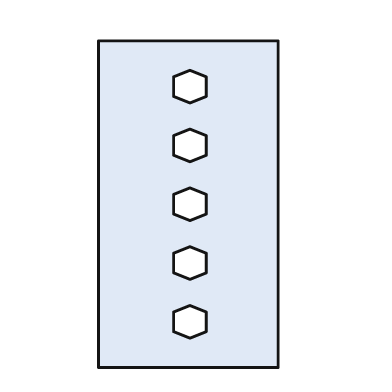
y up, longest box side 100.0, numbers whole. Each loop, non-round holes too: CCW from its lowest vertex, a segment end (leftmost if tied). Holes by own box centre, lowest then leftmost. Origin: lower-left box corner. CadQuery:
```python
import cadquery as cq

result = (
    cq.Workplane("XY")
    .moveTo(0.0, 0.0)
    .lineTo(55.0, 0.0)
    .lineTo(55.0, 100.0)
    .lineTo(0.0, 100.0)
    .close()
    .moveTo(28.0, 9.0)
    .lineTo(33.0, 11.0)
    .lineTo(33.0, 17.0)
    .lineTo(28.0, 19.0)
    .lineTo(23.0, 17.0)
    .lineTo(23.0, 11.0)
    .close()
    .moveTo(28.0, 27.0)
    .lineTo(33.0, 29.0)
    .lineTo(33.0, 35.0)
    .lineTo(28.0, 37.0)
    .lineTo(23.0, 35.0)
    .lineTo(23.0, 29.0)
    .close()
    .moveTo(28.0, 45.0)
    .lineTo(33.0, 47.0)
    .lineTo(33.0, 53.0)
    .lineTo(28.0, 55.0)
    .lineTo(23.0, 53.0)
    .lineTo(23.0, 47.0)
    .close()
    .moveTo(28.0, 63.0)
    .lineTo(33.0, 65.0)
    .lineTo(33.0, 71.0)
    .lineTo(28.0, 73.0)
    .lineTo(23.0, 71.0)
    .lineTo(23.0, 65.0)
    .close()
    .moveTo(28.0, 81.0)
    .lineTo(33.0, 83.0)
    .lineTo(33.0, 89.0)
    .lineTo(28.0, 91.0)
    .lineTo(23.0, 89.0)
    .lineTo(23.0, 83.0)
    .close()
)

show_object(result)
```